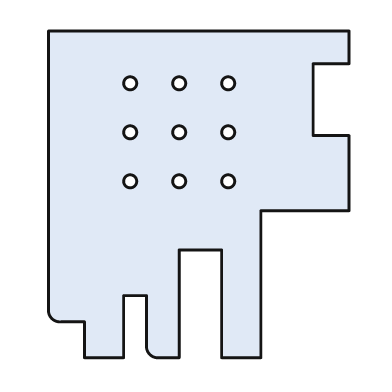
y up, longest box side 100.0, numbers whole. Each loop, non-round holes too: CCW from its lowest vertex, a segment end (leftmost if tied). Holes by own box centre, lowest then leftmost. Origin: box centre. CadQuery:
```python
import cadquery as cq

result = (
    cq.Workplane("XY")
    .moveTo(-35.0, -50.0)
    .lineTo(-23.0, -50.0)
    .lineTo(-23.0, -31.0)
    .lineTo(-16.0, -31.0)
    .lineTo(-16.0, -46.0)
    .threePointArc((-15.0, -49.0), (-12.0, -50.0))
    .lineTo(-6.0, -50.0)
    .lineTo(-6.0, -17.0)
    .lineTo(7.0, -17.0)
    .lineTo(7.0, -50.0)
    .lineTo(19.0, -50.0)
    .lineTo(19.0, -5.0)
    .lineTo(46.0, -5.0)
    .lineTo(46.0, 18.0)
    .lineTo(35.0, 18.0)
    .lineTo(35.0, 40.0)
    .lineTo(46.0, 40.0)
    .lineTo(46.0, 50.0)
    .lineTo(-46.0, 50.0)
    .lineTo(-46.0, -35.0)
    .threePointArc((-45.0, -38.0), (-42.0, -39.0))
    .lineTo(-35.0, -39.0)
    .close()
    .moveTo(-21.0, 4.0)
    .circle(2.0)
    .moveTo(-6.0, 4.0)
    .circle(2.0)
    .moveTo(9.0, 4.0)
    .circle(2.0)
    .moveTo(-21.0, 19.0)
    .circle(2.0)
    .moveTo(-6.0, 19.0)
    .circle(2.0)
    .moveTo(9.0, 19.0)
    .circle(2.0)
    .moveTo(-21.0, 34.0)
    .circle(2.0)
    .moveTo(-6.0, 34.0)
    .circle(2.0)
    .moveTo(9.0, 34.0)
    .circle(2.0)
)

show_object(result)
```